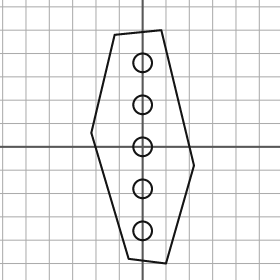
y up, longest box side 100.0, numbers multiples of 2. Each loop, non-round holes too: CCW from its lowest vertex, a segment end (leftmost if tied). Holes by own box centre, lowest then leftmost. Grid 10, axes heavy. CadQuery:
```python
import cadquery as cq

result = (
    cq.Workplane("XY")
    .moveTo(10.0, -50.0)
    .lineTo(22.0, -8.0)
    .lineTo(8.0, 50.0)
    .lineTo(-12.0, 48.0)
    .lineTo(-22.0, 6.0)
    .lineTo(-6.0, -48.0)
    .close()
    .moveTo(0.0, -36.0)
    .circle(4.0)
    .moveTo(0.0, -18.0)
    .circle(4.0)
    .moveTo(0.0, 0.0)
    .circle(4.0)
    .moveTo(0.0, 18.0)
    .circle(4.0)
    .moveTo(0.0, 36.0)
    .circle(4.0)
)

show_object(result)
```